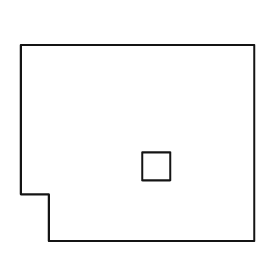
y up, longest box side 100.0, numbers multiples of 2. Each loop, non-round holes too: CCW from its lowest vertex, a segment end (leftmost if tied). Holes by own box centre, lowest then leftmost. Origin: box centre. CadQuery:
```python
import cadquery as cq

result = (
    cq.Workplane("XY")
    .moveTo(-38.0, -42.0)
    .lineTo(50.0, -42.0)
    .lineTo(50.0, 42.0)
    .lineTo(-50.0, 42.0)
    .lineTo(-50.0, -22.0)
    .lineTo(-38.0, -22.0)
    .close()
    .moveTo(2.0, -16.0)
    .lineTo(14.0, -16.0)
    .lineTo(14.0, -4.0)
    .lineTo(2.0, -4.0)
    .close()
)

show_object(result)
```